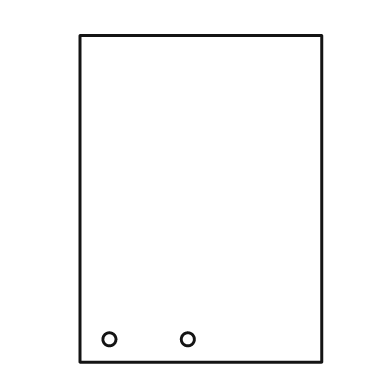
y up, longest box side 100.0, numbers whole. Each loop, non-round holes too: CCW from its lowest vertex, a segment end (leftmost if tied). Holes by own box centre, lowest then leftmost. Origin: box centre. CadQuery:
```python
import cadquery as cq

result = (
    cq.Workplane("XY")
    .moveTo(-37.0, -50.0)
    .lineTo(37.0, -50.0)
    .lineTo(37.0, 50.0)
    .lineTo(-37.0, 50.0)
    .close()
    .moveTo(-28.0, -43.0)
    .circle(2.0)
    .moveTo(-4.0, -43.0)
    .circle(2.0)
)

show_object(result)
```